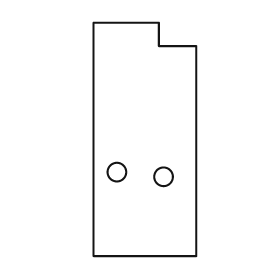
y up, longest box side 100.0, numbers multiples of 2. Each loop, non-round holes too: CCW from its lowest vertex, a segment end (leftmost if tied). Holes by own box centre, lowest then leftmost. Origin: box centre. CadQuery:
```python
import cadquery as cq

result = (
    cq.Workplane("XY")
    .moveTo(-22.0, -50.0)
    .lineTo(22.0, -50.0)
    .lineTo(22.0, 40.0)
    .lineTo(6.0, 40.0)
    .lineTo(6.0, 50.0)
    .lineTo(-22.0, 50.0)
    .close()
    .moveTo(8.0, -16.0)
    .circle(4.0)
    .moveTo(-12.0, -14.0)
    .circle(4.0)
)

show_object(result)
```